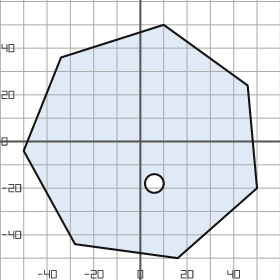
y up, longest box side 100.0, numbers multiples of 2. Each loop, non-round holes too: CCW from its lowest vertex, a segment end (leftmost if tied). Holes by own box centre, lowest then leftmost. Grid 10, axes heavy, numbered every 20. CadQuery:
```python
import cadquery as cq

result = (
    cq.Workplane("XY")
    .moveTo(16.0, -50.0)
    .lineTo(50.0, -20.0)
    .lineTo(46.0, 24.0)
    .lineTo(10.0, 50.0)
    .lineTo(-34.0, 36.0)
    .lineTo(-50.0, -4.0)
    .lineTo(-28.0, -44.0)
    .close()
    .moveTo(6.0, -18.0)
    .circle(4.0)
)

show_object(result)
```